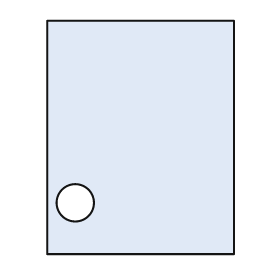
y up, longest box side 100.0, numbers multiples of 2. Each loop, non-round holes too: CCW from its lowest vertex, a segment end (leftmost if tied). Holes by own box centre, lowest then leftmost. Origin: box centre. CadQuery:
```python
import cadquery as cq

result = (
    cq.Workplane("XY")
    .moveTo(-40.0, -50.0)
    .lineTo(40.0, -50.0)
    .lineTo(40.0, 50.0)
    .lineTo(-40.0, 50.0)
    .close()
    .moveTo(-28.0, -28.0)
    .circle(8.0)
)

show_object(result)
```